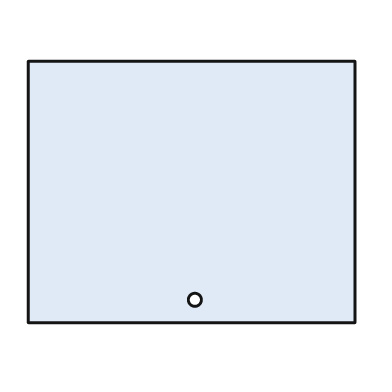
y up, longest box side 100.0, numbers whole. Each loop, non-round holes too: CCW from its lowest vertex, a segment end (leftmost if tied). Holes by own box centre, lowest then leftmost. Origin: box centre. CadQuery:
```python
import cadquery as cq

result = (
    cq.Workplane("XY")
    .moveTo(-50.0, -40.0)
    .lineTo(50.0, -40.0)
    .lineTo(50.0, 40.0)
    .lineTo(-50.0, 40.0)
    .close()
    .moveTo(1.0, -33.0)
    .circle(2.0)
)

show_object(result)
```